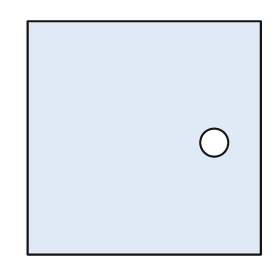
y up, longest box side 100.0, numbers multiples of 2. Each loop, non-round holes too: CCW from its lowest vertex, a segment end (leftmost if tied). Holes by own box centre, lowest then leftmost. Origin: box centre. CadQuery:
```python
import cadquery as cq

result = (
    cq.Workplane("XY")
    .moveTo(-50.0, -50.0)
    .lineTo(50.0, -50.0)
    .lineTo(50.0, 50.0)
    .lineTo(-50.0, 50.0)
    .close()
    .moveTo(30.0, -2.0)
    .circle(6.0)
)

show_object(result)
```